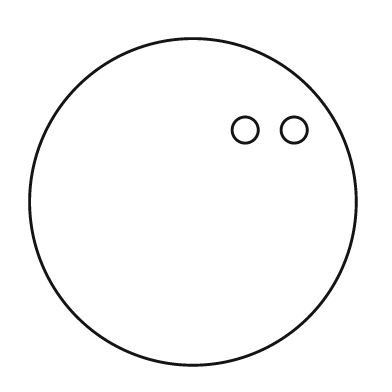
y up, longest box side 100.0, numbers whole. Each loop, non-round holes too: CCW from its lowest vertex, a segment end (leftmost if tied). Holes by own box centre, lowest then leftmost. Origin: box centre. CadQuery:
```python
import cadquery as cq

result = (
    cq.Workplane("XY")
    .moveTo(0.0, 0.0)
    .circle(50.0)
    .moveTo(16.0, 22.0)
    .circle(4.0)
    .moveTo(31.0, 22.0)
    .circle(4.0)
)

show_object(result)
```